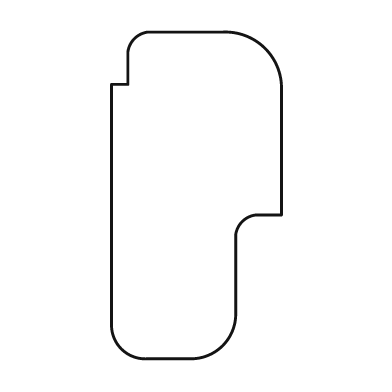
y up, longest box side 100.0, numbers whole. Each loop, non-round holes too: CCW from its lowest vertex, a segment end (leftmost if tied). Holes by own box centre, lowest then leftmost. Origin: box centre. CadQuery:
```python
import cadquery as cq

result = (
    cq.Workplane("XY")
    .moveTo(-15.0, -50.0)
    .lineTo(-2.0, -50.0)
    .threePointArc((8.0, -46.0), (12.0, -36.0))
    .lineTo(12.0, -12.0)
    .threePointArc((14.0, -8.0), (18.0, -6.0))
    .lineTo(26.0, -6.0)
    .lineTo(26.0, 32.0)
    .threePointArc((21.0, 45.0), (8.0, 50.0))
    .lineTo(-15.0, 50.0)
    .threePointArc((-19.0, 48.0), (-21.0, 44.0))
    .lineTo(-21.0, 34.0)
    .lineTo(-26.0, 34.0)
    .lineTo(-26.0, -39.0)
    .threePointArc((-23.0, -47.0), (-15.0, -50.0))
    .close()
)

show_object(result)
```